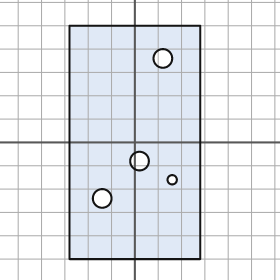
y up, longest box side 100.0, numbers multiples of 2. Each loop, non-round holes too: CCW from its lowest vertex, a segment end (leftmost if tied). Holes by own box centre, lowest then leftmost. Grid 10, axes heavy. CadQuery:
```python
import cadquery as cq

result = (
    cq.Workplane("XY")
    .moveTo(-28.0, -50.0)
    .lineTo(28.0, -50.0)
    .lineTo(28.0, 50.0)
    .lineTo(-28.0, 50.0)
    .close()
    .moveTo(-14.0, -24.0)
    .circle(4.0)
    .moveTo(16.0, -16.0)
    .circle(2.0)
    .moveTo(2.0, -8.0)
    .circle(4.0)
    .moveTo(12.0, 36.0)
    .circle(4.0)
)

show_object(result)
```